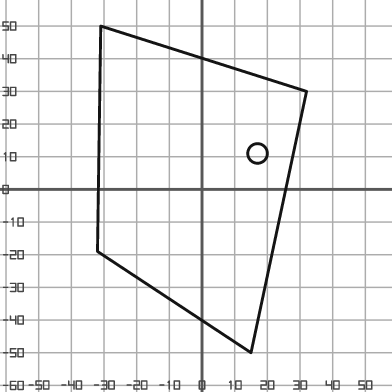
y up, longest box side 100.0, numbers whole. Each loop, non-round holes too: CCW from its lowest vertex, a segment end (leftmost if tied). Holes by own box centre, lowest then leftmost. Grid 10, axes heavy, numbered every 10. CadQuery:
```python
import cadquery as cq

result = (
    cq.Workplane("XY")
    .moveTo(15.0, -50.0)
    .lineTo(32.0, 30.0)
    .lineTo(-31.0, 50.0)
    .lineTo(-32.0, -19.0)
    .close()
    .moveTo(17.0, 11.0)
    .circle(3.0)
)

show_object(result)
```